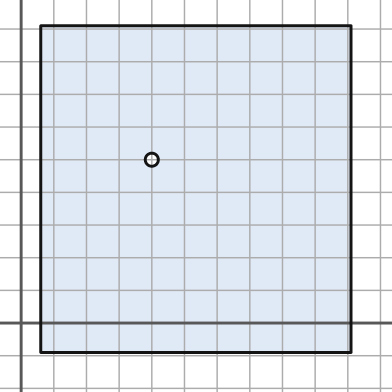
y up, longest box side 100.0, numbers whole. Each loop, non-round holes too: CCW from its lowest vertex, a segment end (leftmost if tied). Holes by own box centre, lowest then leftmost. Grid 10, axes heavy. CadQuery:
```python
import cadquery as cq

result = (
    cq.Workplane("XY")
    .moveTo(6.0, -9.0)
    .lineTo(101.0, -9.0)
    .lineTo(101.0, 91.0)
    .lineTo(6.0, 91.0)
    .close()
    .moveTo(40.0, 50.0)
    .circle(2.0)
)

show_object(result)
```